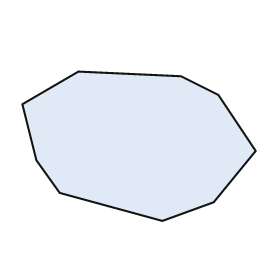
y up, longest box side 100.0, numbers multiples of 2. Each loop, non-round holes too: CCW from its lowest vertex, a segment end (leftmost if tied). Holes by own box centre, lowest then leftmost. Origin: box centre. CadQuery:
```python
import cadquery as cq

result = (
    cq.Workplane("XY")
    .moveTo(10.0, -32.0)
    .lineTo(32.0, -24.0)
    .lineTo(50.0, -2.0)
    .lineTo(34.0, 22.0)
    .lineTo(18.0, 30.0)
    .lineTo(-26.0, 32.0)
    .lineTo(-50.0, 18.0)
    .lineTo(-44.0, -6.0)
    .lineTo(-34.0, -20.0)
    .close()
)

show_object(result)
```